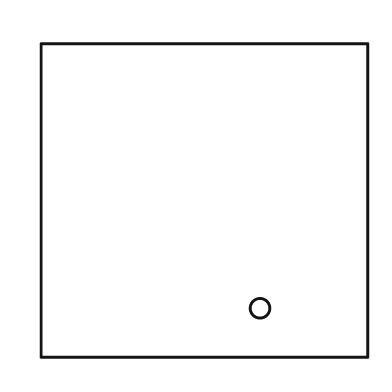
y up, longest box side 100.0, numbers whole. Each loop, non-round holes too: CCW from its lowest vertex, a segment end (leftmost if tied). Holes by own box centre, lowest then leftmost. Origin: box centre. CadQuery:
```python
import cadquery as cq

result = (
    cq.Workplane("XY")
    .moveTo(-50.0, -48.0)
    .lineTo(50.0, -48.0)
    .lineTo(50.0, 48.0)
    .lineTo(-50.0, 48.0)
    .close()
    .moveTo(17.0, -33.0)
    .circle(3.0)
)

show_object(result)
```